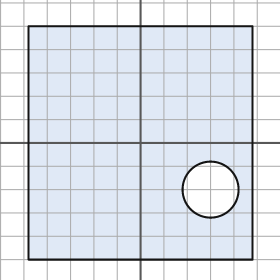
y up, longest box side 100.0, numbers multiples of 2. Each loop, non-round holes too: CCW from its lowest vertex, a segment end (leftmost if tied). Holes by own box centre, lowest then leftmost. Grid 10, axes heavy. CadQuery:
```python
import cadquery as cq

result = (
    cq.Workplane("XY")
    .moveTo(-48.0, -50.0)
    .lineTo(48.0, -50.0)
    .lineTo(48.0, 50.0)
    .lineTo(-48.0, 50.0)
    .close()
    .moveTo(30.0, -20.0)
    .circle(12.0)
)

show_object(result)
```